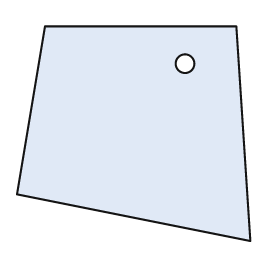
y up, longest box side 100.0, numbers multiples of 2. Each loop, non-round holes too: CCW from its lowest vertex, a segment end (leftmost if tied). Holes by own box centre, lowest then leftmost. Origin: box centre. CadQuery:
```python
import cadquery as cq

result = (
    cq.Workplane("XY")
    .moveTo(50.0, -46.0)
    .lineTo(44.0, 46.0)
    .lineTo(-38.0, 46.0)
    .lineTo(-50.0, -26.0)
    .close()
    .moveTo(22.0, 30.0)
    .circle(4.0)
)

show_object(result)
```